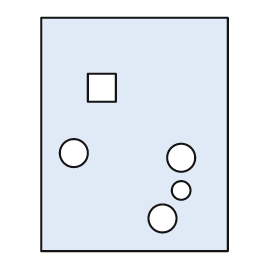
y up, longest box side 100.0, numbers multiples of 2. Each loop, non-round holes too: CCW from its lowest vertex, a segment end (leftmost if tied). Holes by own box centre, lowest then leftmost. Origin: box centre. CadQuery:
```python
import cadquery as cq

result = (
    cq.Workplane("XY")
    .moveTo(-40.0, -50.0)
    .lineTo(40.0, -50.0)
    .lineTo(40.0, 50.0)
    .lineTo(-40.0, 50.0)
    .close()
    .moveTo(12.0, -36.0)
    .circle(6.0)
    .moveTo(20.0, -24.0)
    .circle(4.0)
    .moveTo(20.0, -10.0)
    .circle(6.0)
    .moveTo(-26.0, -8.0)
    .circle(6.0)
    .moveTo(-20.0, 14.0)
    .lineTo(-8.0, 14.0)
    .lineTo(-8.0, 26.0)
    .lineTo(-20.0, 26.0)
    .close()
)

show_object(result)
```